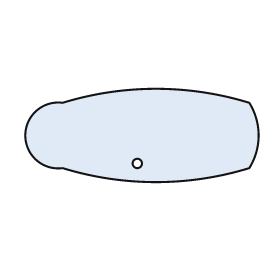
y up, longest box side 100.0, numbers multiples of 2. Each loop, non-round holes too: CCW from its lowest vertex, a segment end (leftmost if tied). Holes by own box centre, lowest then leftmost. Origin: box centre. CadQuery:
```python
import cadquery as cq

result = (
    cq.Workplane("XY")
    .moveTo(-34.0, -14.0)
    .threePointArc((6.0, -20.0), (46.0, -14.0))
    .threePointArc((50.0, 0.0), (46.0, 14.0))
    .threePointArc((6.0, 20.0), (-34.0, 14.0))
    .threePointArc((-50.0, 0.0), (-34.0, -14.0))
    .close()
    .moveTo(-2.0, -12.0)
    .circle(2.0)
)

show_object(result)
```